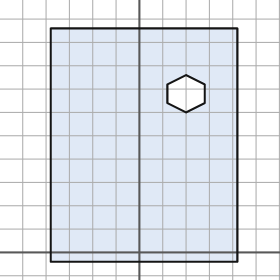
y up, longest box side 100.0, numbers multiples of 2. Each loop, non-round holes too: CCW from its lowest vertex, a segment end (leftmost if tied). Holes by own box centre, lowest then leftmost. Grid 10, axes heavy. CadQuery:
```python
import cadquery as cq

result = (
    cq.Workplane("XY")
    .moveTo(-38.0, -4.0)
    .lineTo(42.0, -4.0)
    .lineTo(42.0, 96.0)
    .lineTo(-38.0, 96.0)
    .close()
    .moveTo(20.0, 60.0)
    .lineTo(28.0, 64.0)
    .lineTo(28.0, 72.0)
    .lineTo(20.0, 76.0)
    .lineTo(12.0, 72.0)
    .lineTo(12.0, 64.0)
    .close()
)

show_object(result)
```